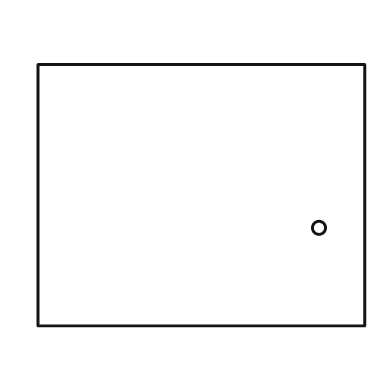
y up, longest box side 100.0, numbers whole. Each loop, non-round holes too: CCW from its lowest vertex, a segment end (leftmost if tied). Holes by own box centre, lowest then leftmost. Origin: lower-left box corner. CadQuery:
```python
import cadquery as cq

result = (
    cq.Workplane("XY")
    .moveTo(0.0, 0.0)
    .lineTo(100.0, 0.0)
    .lineTo(100.0, 80.0)
    .lineTo(0.0, 80.0)
    .close()
    .moveTo(86.0, 30.0)
    .circle(2.0)
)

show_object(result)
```